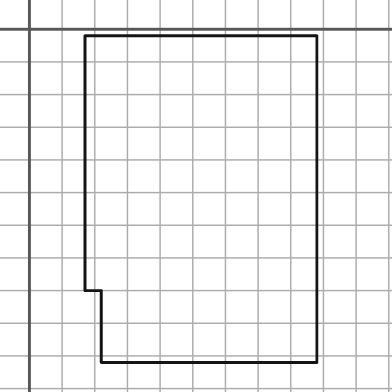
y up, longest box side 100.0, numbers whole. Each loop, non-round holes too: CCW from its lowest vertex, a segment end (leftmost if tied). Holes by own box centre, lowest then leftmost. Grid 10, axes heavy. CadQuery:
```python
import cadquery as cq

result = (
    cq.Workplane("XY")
    .moveTo(22.0, -102.0)
    .lineTo(88.0, -102.0)
    .lineTo(88.0, -2.0)
    .lineTo(17.0, -2.0)
    .lineTo(17.0, -80.0)
    .lineTo(22.0, -80.0)
    .close()
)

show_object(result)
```